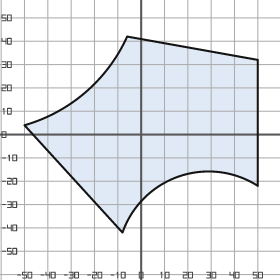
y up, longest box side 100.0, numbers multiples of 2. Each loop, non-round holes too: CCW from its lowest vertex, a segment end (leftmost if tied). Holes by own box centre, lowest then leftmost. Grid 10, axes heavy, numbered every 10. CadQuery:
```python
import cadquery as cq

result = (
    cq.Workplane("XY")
    .moveTo(-8.0, -42.0)
    .threePointArc((16.0, -18.0), (50.0, -22.0))
    .lineTo(50.0, 32.0)
    .lineTo(-6.0, 42.0)
    .threePointArc((-24.0, 18.0), (-50.0, 4.0))
    .close()
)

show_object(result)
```